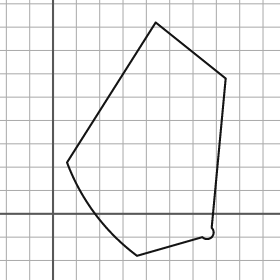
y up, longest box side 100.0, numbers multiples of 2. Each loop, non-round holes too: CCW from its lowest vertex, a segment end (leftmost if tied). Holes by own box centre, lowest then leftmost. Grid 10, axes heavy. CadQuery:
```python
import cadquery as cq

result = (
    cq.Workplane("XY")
    .moveTo(36.0, -18.0)
    .lineTo(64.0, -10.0)
    .threePointArc((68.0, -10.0), (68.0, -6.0))
    .lineTo(74.0, 58.0)
    .lineTo(44.0, 82.0)
    .lineTo(6.0, 22.0)
    .threePointArc((18.0, 0.0), (36.0, -18.0))
    .close()
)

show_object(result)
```